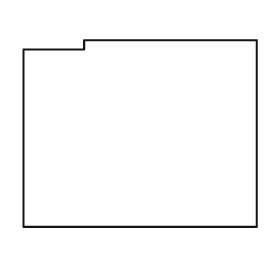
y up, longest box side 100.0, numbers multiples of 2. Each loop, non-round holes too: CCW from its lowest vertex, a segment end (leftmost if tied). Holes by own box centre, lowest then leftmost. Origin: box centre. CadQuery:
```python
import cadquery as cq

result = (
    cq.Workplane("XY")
    .moveTo(-50.0, -40.0)
    .lineTo(50.0, -40.0)
    .lineTo(50.0, 40.0)
    .lineTo(-24.0, 40.0)
    .lineTo(-24.0, 36.0)
    .lineTo(-50.0, 36.0)
    .close()
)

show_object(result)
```